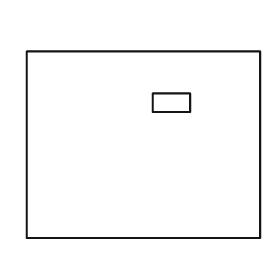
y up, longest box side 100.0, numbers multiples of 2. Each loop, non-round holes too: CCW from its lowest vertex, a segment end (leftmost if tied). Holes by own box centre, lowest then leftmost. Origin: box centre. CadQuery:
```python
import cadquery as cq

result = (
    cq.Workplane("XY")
    .moveTo(-50.0, -40.0)
    .lineTo(50.0, -40.0)
    .lineTo(50.0, 40.0)
    .lineTo(-50.0, 40.0)
    .close()
    .moveTo(4.0, 14.0)
    .lineTo(20.0, 14.0)
    .lineTo(20.0, 22.0)
    .lineTo(4.0, 22.0)
    .close()
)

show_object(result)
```